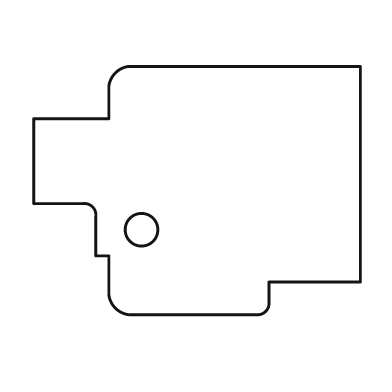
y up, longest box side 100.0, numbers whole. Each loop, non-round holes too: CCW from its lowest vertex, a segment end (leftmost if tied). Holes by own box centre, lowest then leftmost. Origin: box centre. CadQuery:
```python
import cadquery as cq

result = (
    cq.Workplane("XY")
    .moveTo(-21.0, -38.0)
    .lineTo(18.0, -38.0)
    .threePointArc((21.0, -37.0), (22.0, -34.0))
    .lineTo(22.0, -28.0)
    .lineTo(50.0, -28.0)
    .lineTo(50.0, 38.0)
    .lineTo(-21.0, 38.0)
    .threePointArc((-25.0, 36.0), (-27.0, 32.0))
    .lineTo(-27.0, 22.0)
    .lineTo(-50.0, 22.0)
    .lineTo(-50.0, -4.0)
    .lineTo(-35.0, -4.0)
    .threePointArc((-32.0, -5.0), (-31.0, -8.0))
    .lineTo(-31.0, -20.0)
    .lineTo(-27.0, -20.0)
    .lineTo(-27.0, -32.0)
    .threePointArc((-25.0, -36.0), (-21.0, -38.0))
    .close()
    .moveTo(-17.0, -12.0)
    .circle(5.0)
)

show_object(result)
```